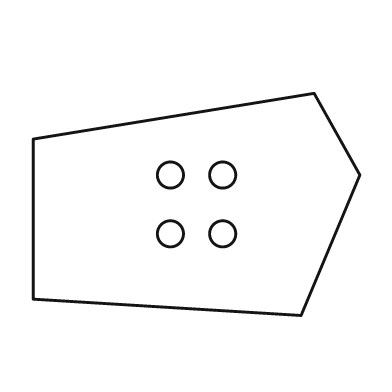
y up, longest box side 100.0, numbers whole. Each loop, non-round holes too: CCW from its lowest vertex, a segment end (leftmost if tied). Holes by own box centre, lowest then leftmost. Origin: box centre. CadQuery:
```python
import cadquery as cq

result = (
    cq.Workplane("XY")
    .moveTo(32.0, -34.0)
    .lineTo(50.0, 9.0)
    .lineTo(36.0, 34.0)
    .lineTo(-50.0, 20.0)
    .lineTo(-50.0, -29.0)
    .close()
    .moveTo(-8.0, -9.0)
    .circle(4.0)
    .moveTo(8.0, -9.0)
    .circle(4.0)
    .moveTo(-8.0, 9.0)
    .circle(4.0)
    .moveTo(8.0, 9.0)
    .circle(4.0)
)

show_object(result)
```